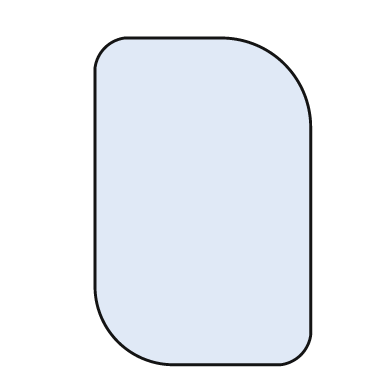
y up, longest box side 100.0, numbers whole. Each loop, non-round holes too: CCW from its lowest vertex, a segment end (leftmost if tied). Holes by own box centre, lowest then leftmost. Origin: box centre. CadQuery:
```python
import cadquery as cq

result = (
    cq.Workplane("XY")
    .moveTo(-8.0, -50.0)
    .lineTo(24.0, -50.0)
    .threePointArc((30.0, -47.0), (33.0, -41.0))
    .lineTo(33.0, 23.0)
    .threePointArc((25.0, 42.0), (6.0, 50.0))
    .lineTo(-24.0, 50.0)
    .threePointArc((-30.0, 47.0), (-33.0, 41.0))
    .lineTo(-33.0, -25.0)
    .threePointArc((-26.0, -43.0), (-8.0, -50.0))
    .close()
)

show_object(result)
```